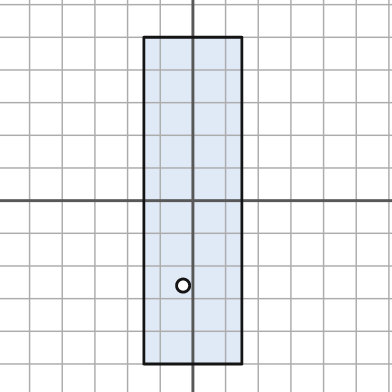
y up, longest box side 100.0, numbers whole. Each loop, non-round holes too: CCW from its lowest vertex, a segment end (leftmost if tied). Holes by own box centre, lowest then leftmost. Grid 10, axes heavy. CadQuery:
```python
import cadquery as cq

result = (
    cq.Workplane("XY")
    .moveTo(-15.0, -50.0)
    .lineTo(15.0, -50.0)
    .lineTo(15.0, 50.0)
    .lineTo(-15.0, 50.0)
    .close()
    .moveTo(-3.0, -26.0)
    .circle(2.0)
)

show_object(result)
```